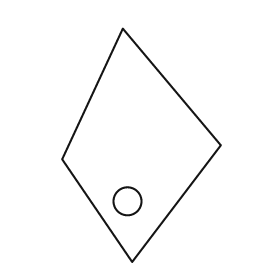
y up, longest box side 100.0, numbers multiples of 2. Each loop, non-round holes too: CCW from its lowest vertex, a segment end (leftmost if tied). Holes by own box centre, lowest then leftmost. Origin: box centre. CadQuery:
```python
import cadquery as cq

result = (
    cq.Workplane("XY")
    .moveTo(-4.0, -50.0)
    .lineTo(34.0, 0.0)
    .lineTo(-8.0, 50.0)
    .lineTo(-34.0, -6.0)
    .close()
    .moveTo(-6.0, -24.0)
    .circle(6.0)
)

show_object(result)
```